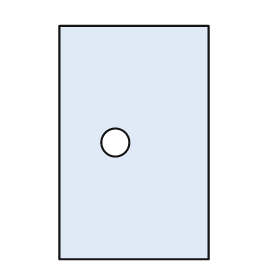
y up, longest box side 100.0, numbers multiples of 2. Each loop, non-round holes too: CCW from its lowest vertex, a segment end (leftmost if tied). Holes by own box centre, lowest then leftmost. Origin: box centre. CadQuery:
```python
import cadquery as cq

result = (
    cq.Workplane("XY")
    .moveTo(-32.0, -50.0)
    .lineTo(32.0, -50.0)
    .lineTo(32.0, 50.0)
    .lineTo(-32.0, 50.0)
    .close()
    .moveTo(-8.0, 0.0)
    .circle(6.0)
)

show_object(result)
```